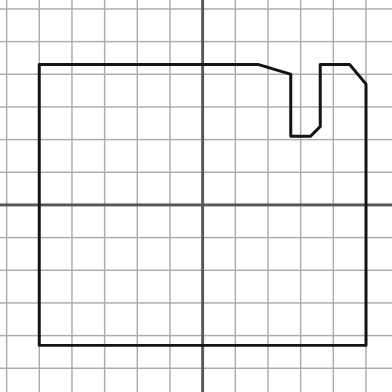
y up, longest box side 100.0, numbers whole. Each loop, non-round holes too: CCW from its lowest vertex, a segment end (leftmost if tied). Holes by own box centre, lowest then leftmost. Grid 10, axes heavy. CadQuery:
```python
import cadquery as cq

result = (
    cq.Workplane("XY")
    .moveTo(-50.0, -43.0)
    .lineTo(50.0, -43.0)
    .lineTo(50.0, 37.0)
    .lineTo(45.0, 43.0)
    .lineTo(36.0, 43.0)
    .lineTo(36.0, 24.0)
    .lineTo(33.0, 21.0)
    .lineTo(27.0, 21.0)
    .lineTo(27.0, 40.0)
    .lineTo(17.0, 43.0)
    .lineTo(-50.0, 43.0)
    .close()
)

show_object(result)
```